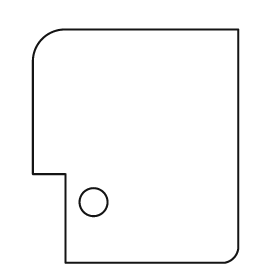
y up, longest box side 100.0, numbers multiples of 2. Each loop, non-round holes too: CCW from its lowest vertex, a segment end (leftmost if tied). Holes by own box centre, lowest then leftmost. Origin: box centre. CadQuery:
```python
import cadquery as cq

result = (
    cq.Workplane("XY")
    .moveTo(-30.0, -50.0)
    .lineTo(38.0, -50.0)
    .threePointArc((42.0, -48.0), (44.0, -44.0))
    .lineTo(44.0, 50.0)
    .lineTo(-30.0, 50.0)
    .threePointArc((-40.0, 46.0), (-44.0, 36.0))
    .lineTo(-44.0, -12.0)
    .lineTo(-30.0, -12.0)
    .close()
    .moveTo(-18.0, -24.0)
    .circle(6.0)
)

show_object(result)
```